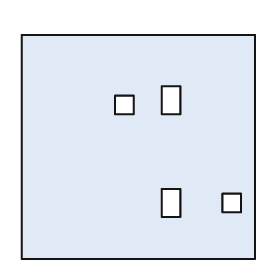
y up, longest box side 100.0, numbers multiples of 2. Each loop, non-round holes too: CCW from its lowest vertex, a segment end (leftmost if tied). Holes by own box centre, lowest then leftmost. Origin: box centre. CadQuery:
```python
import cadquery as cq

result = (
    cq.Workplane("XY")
    .moveTo(-50.0, -48.0)
    .lineTo(50.0, -48.0)
    .lineTo(50.0, 48.0)
    .lineTo(-50.0, 48.0)
    .close()
    .moveTo(10.0, -30.0)
    .lineTo(18.0, -30.0)
    .lineTo(18.0, -18.0)
    .lineTo(10.0, -18.0)
    .close()
    .moveTo(36.0, -28.0)
    .lineTo(44.0, -28.0)
    .lineTo(44.0, -20.0)
    .lineTo(36.0, -20.0)
    .close()
    .moveTo(-10.0, 14.0)
    .lineTo(-2.0, 14.0)
    .lineTo(-2.0, 22.0)
    .lineTo(-10.0, 22.0)
    .close()
    .moveTo(10.0, 14.0)
    .lineTo(18.0, 14.0)
    .lineTo(18.0, 26.0)
    .lineTo(10.0, 26.0)
    .close()
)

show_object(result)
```